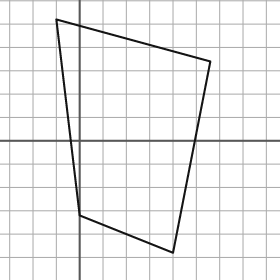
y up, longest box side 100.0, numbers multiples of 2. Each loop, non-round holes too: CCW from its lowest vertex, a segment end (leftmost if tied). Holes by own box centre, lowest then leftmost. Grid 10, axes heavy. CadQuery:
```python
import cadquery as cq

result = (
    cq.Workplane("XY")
    .moveTo(40.0, -48.0)
    .lineTo(56.0, 34.0)
    .lineTo(-10.0, 52.0)
    .lineTo(0.0, -32.0)
    .close()
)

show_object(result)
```